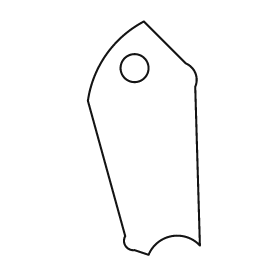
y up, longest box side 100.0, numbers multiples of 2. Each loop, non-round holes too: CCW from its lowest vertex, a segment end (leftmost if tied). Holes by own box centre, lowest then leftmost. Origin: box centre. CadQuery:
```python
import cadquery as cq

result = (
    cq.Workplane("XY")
    .moveTo(2.0, -50.0)
    .threePointArc((12.0, -42.0), (24.0, -46.0))
    .lineTo(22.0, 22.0)
    .threePointArc((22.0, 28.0), (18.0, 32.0))
    .lineTo(0.0, 50.0)
    .threePointArc((-16.0, 36.0), (-24.0, 16.0))
    .lineTo(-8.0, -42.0)
    .threePointArc((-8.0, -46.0), (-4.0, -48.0))
    .close()
    .moveTo(-4.0, 30.0)
    .circle(6.0)
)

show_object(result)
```